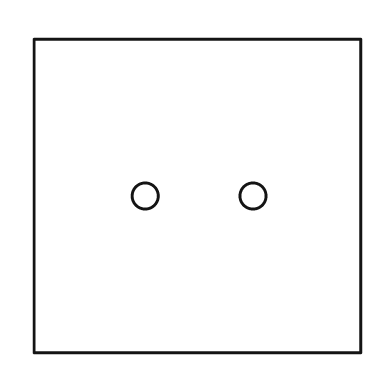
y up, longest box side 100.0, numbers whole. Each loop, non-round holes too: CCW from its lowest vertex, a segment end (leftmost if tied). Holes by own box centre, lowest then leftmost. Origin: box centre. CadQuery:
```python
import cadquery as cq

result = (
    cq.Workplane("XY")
    .moveTo(-50.0, -48.0)
    .lineTo(50.0, -48.0)
    .lineTo(50.0, 48.0)
    .lineTo(-50.0, 48.0)
    .close()
    .moveTo(-16.0, 0.0)
    .circle(4.0)
    .moveTo(17.0, 0.0)
    .circle(4.0)
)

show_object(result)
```